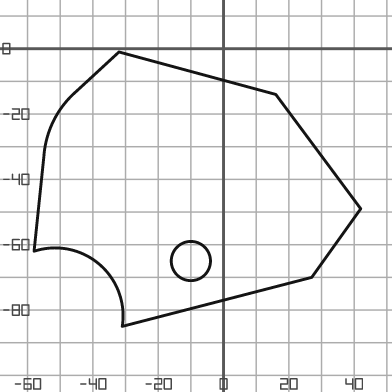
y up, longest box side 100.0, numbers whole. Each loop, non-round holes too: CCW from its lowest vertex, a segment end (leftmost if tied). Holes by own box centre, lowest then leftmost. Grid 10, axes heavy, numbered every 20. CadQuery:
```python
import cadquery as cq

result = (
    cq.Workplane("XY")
    .moveTo(-31.0, -85.0)
    .lineTo(27.0, -70.0)
    .lineTo(42.0, -49.0)
    .lineTo(16.0, -14.0)
    .lineTo(-32.0, -1.0)
    .lineTo(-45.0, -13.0)
    .threePointArc((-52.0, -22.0), (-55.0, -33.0))
    .lineTo(-58.0, -62.0)
    .threePointArc((-38.0, -66.0), (-31.0, -85.0))
    .close()
    .moveTo(-10.0, -65.0)
    .circle(6.0)
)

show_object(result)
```